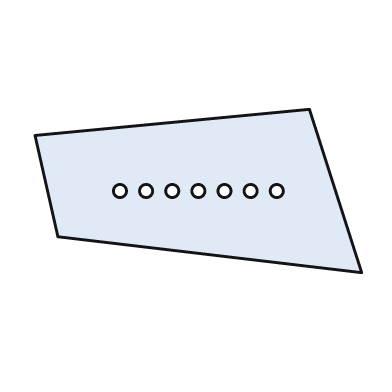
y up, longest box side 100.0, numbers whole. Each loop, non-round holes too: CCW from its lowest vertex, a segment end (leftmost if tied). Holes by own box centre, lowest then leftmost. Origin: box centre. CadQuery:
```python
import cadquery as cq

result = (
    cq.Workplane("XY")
    .moveTo(50.0, -25.0)
    .lineTo(34.0, 25.0)
    .lineTo(-50.0, 17.0)
    .lineTo(-43.0, -14.0)
    .close()
    .moveTo(-24.0, 0.0)
    .circle(2.0)
    .moveTo(-16.0, 0.0)
    .circle(2.0)
    .moveTo(-8.0, 0.0)
    .circle(2.0)
    .moveTo(0.0, 0.0)
    .circle(2.0)
    .moveTo(8.0, 0.0)
    .circle(2.0)
    .moveTo(16.0, 0.0)
    .circle(2.0)
    .moveTo(24.0, 0.0)
    .circle(2.0)
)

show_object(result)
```